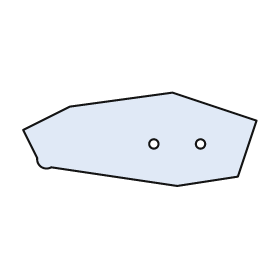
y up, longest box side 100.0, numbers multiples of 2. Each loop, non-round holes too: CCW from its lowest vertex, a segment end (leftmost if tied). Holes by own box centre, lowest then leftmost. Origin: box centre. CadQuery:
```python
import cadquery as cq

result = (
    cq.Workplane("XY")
    .moveTo(16.0, -20.0)
    .lineTo(42.0, -16.0)
    .lineTo(50.0, 8.0)
    .lineTo(14.0, 20.0)
    .lineTo(-30.0, 14.0)
    .lineTo(-50.0, 4.0)
    .lineTo(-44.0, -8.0)
    .threePointArc((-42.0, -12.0), (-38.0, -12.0))
    .close()
    .moveTo(6.0, -2.0)
    .circle(2.0)
    .moveTo(26.0, -2.0)
    .circle(2.0)
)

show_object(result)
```